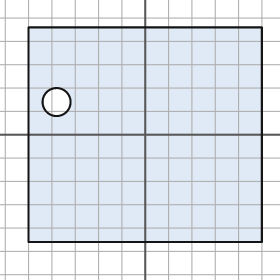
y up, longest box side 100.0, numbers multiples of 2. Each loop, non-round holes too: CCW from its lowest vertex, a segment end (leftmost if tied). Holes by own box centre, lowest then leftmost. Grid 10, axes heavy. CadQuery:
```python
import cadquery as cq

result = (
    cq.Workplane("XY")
    .moveTo(-50.0, -46.0)
    .lineTo(50.0, -46.0)
    .lineTo(50.0, 46.0)
    .lineTo(-50.0, 46.0)
    .close()
    .moveTo(-38.0, 14.0)
    .circle(6.0)
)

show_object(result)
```